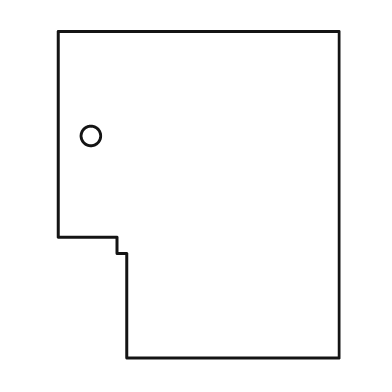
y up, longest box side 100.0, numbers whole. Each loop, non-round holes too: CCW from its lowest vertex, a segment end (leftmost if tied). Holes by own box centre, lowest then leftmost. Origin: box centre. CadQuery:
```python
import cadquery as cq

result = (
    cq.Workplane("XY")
    .moveTo(-22.0, -50.0)
    .lineTo(43.0, -50.0)
    .lineTo(43.0, 50.0)
    .lineTo(-43.0, 50.0)
    .lineTo(-43.0, -13.0)
    .lineTo(-25.0, -13.0)
    .lineTo(-25.0, -18.0)
    .lineTo(-22.0, -18.0)
    .close()
    .moveTo(-33.0, 18.0)
    .circle(3.0)
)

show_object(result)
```